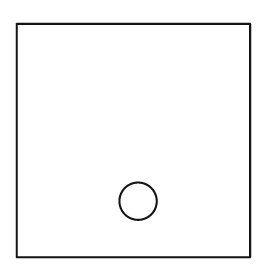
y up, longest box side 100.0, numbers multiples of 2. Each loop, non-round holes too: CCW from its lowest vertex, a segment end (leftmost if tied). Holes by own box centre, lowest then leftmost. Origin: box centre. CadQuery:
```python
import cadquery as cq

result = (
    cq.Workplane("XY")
    .moveTo(-50.0, -50.0)
    .lineTo(50.0, -50.0)
    .lineTo(50.0, 50.0)
    .lineTo(-50.0, 50.0)
    .close()
    .moveTo(2.0, -26.0)
    .circle(8.0)
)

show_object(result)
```